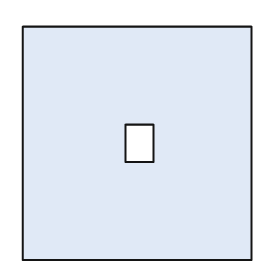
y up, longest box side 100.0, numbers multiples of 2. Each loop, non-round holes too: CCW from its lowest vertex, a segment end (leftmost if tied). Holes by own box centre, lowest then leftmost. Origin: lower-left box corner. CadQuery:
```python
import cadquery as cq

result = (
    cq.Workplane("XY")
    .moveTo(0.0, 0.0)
    .lineTo(98.0, 0.0)
    .lineTo(98.0, 100.0)
    .lineTo(0.0, 100.0)
    .close()
    .moveTo(44.0, 42.0)
    .lineTo(56.0, 42.0)
    .lineTo(56.0, 58.0)
    .lineTo(44.0, 58.0)
    .close()
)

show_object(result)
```